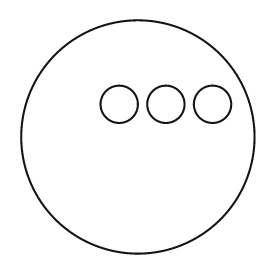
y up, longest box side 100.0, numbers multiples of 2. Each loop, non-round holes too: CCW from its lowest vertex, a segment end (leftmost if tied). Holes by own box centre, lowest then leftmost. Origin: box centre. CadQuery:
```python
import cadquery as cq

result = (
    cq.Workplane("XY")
    .moveTo(0.0, 0.0)
    .circle(50.0)
    .moveTo(-8.0, 14.0)
    .circle(8.0)
    .moveTo(12.0, 14.0)
    .circle(8.0)
    .moveTo(32.0, 14.0)
    .circle(8.0)
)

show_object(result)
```